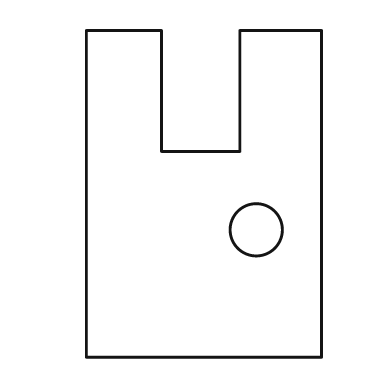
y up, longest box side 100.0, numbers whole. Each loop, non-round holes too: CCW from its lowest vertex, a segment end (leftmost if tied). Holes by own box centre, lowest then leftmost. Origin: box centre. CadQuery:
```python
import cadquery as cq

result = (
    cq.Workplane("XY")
    .moveTo(-36.0, -50.0)
    .lineTo(36.0, -50.0)
    .lineTo(36.0, 50.0)
    .lineTo(11.0, 50.0)
    .lineTo(11.0, 13.0)
    .lineTo(-13.0, 13.0)
    .lineTo(-13.0, 50.0)
    .lineTo(-36.0, 50.0)
    .close()
    .moveTo(16.0, -11.0)
    .circle(8.0)
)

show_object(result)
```